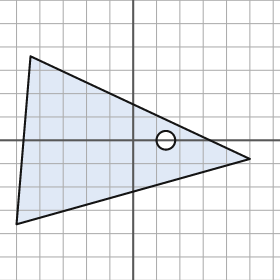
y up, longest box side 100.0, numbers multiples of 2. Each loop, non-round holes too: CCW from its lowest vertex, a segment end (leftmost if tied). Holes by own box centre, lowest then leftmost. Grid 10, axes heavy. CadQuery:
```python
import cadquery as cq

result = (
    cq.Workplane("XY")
    .moveTo(-50.0, -36.0)
    .lineTo(50.0, -8.0)
    .lineTo(-44.0, 36.0)
    .close()
    .moveTo(14.0, 0.0)
    .circle(4.0)
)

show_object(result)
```